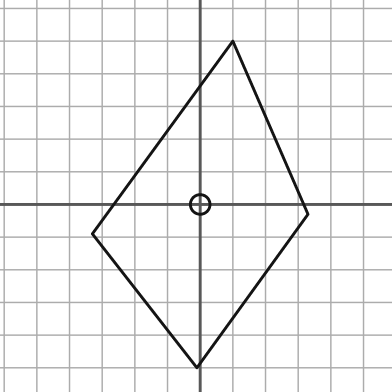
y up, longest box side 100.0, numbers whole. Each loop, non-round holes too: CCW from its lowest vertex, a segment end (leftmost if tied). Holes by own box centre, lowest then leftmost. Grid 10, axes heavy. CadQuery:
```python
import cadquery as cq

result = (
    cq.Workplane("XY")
    .moveTo(-1.0, -50.0)
    .lineTo(33.0, -3.0)
    .lineTo(10.0, 50.0)
    .lineTo(-33.0, -9.0)
    .close()
    .moveTo(0.0, 0.0)
    .circle(3.0)
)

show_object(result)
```